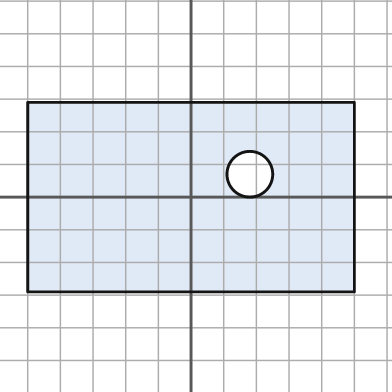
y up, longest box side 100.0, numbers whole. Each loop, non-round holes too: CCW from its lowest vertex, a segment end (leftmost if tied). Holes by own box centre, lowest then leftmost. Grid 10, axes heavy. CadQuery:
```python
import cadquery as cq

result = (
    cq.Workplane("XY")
    .moveTo(-50.0, -29.0)
    .lineTo(50.0, -29.0)
    .lineTo(50.0, 29.0)
    .lineTo(-50.0, 29.0)
    .close()
    .moveTo(18.0, 7.0)
    .circle(7.0)
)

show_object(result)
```